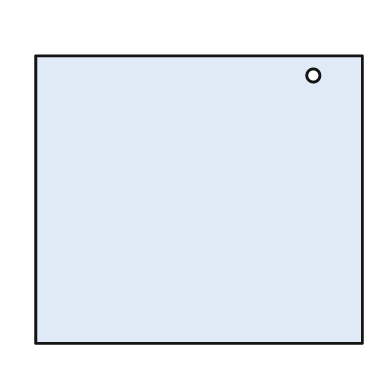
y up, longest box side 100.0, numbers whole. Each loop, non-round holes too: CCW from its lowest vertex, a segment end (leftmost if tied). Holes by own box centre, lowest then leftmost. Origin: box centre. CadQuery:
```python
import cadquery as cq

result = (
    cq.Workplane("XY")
    .moveTo(-50.0, -44.0)
    .lineTo(50.0, -44.0)
    .lineTo(50.0, 44.0)
    .lineTo(-50.0, 44.0)
    .close()
    .moveTo(35.0, 38.0)
    .circle(2.0)
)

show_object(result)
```